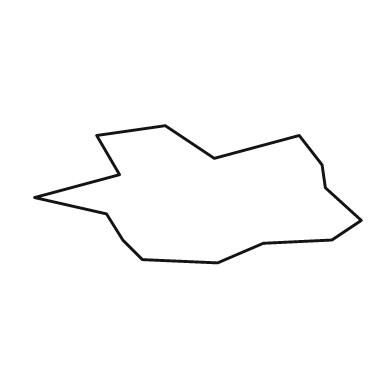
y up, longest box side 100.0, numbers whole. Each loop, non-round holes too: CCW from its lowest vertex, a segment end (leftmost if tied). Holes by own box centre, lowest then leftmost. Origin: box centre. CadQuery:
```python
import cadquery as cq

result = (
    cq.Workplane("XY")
    .moveTo(6.0, -21.0)
    .lineTo(20.0, -15.0)
    .lineTo(41.0, -14.0)
    .lineTo(50.0, -8.0)
    .lineTo(39.0, 2.0)
    .lineTo(38.0, 9.0)
    .lineTo(31.0, 18.0)
    .lineTo(5.0, 11.0)
    .lineTo(-10.0, 21.0)
    .lineTo(-31.0, 18.0)
    .lineTo(-24.0, 6.0)
    .lineTo(-50.0, -1.0)
    .lineTo(-28.0, -6.0)
    .lineTo(-23.0, -14.0)
    .lineTo(-17.0, -20.0)
    .close()
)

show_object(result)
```